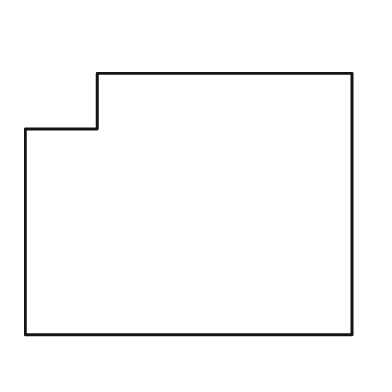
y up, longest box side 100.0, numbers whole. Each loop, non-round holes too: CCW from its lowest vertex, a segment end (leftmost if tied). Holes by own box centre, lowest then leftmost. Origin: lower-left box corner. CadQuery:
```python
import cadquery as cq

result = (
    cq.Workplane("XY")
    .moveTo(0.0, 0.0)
    .lineTo(100.0, 0.0)
    .lineTo(100.0, 80.0)
    .lineTo(22.0, 80.0)
    .lineTo(22.0, 63.0)
    .lineTo(0.0, 63.0)
    .close()
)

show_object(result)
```